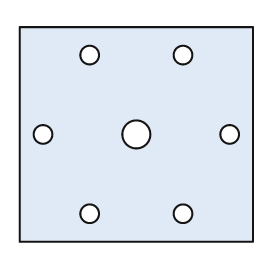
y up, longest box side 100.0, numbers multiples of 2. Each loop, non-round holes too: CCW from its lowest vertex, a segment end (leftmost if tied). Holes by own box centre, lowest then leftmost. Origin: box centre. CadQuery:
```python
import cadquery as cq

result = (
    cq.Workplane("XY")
    .moveTo(-50.0, -46.0)
    .lineTo(50.0, -46.0)
    .lineTo(50.0, 46.0)
    .lineTo(-50.0, 46.0)
    .close()
    .moveTo(-20.0, -34.0)
    .circle(4.0)
    .moveTo(20.0, -34.0)
    .circle(4.0)
    .moveTo(-40.0, 0.0)
    .circle(4.0)
    .moveTo(0.0, 0.0)
    .circle(6.0)
    .moveTo(40.0, 0.0)
    .circle(4.0)
    .moveTo(-20.0, 34.0)
    .circle(4.0)
    .moveTo(20.0, 34.0)
    .circle(4.0)
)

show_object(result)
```